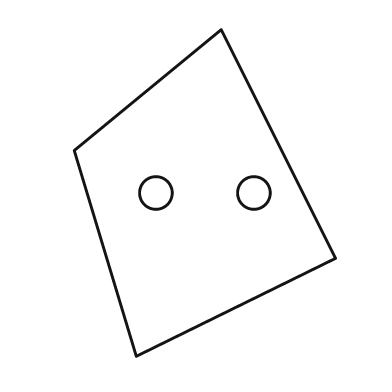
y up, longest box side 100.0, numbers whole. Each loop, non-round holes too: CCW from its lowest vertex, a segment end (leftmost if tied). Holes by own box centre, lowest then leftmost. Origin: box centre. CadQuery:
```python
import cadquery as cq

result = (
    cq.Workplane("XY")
    .moveTo(-21.0, -50.0)
    .lineTo(40.0, -20.0)
    .lineTo(5.0, 50.0)
    .lineTo(-40.0, 13.0)
    .close()
    .moveTo(-15.0, 0.0)
    .circle(5.0)
    .moveTo(15.0, 0.0)
    .circle(5.0)
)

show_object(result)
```